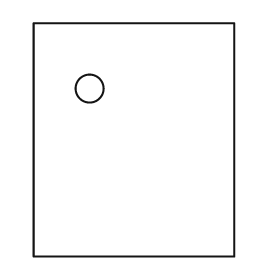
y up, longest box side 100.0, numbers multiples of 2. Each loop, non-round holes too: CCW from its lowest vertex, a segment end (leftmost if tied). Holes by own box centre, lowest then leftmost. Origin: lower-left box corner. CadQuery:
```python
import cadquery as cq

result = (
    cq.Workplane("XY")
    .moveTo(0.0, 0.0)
    .lineTo(86.0, 0.0)
    .lineTo(86.0, 100.0)
    .lineTo(0.0, 100.0)
    .close()
    .moveTo(24.0, 72.0)
    .circle(6.0)
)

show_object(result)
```